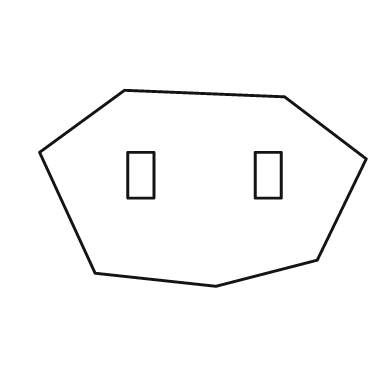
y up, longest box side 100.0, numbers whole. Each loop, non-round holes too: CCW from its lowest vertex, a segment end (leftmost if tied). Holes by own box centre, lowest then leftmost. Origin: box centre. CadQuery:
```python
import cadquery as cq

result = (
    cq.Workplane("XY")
    .moveTo(4.0, -30.0)
    .lineTo(35.0, -22.0)
    .lineTo(50.0, 9.0)
    .lineTo(25.0, 28.0)
    .lineTo(-24.0, 30.0)
    .lineTo(-50.0, 11.0)
    .lineTo(-33.0, -26.0)
    .close()
    .moveTo(-23.0, -3.0)
    .lineTo(-15.0, -3.0)
    .lineTo(-15.0, 11.0)
    .lineTo(-23.0, 11.0)
    .close()
    .moveTo(16.0, -3.0)
    .lineTo(24.0, -3.0)
    .lineTo(24.0, 11.0)
    .lineTo(16.0, 11.0)
    .close()
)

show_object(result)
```